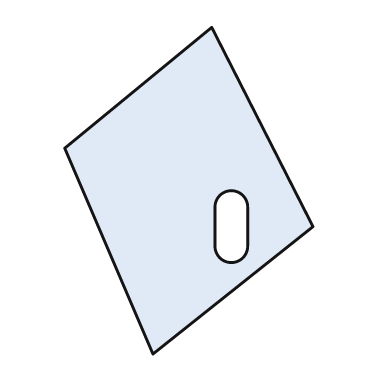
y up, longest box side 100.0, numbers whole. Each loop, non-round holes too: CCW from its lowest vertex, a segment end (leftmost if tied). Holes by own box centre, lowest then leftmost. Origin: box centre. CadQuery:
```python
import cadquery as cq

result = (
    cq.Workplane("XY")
    .moveTo(-11.0, -50.0)
    .lineTo(38.0, -11.0)
    .lineTo(7.0, 50.0)
    .lineTo(-38.0, 13.0)
    .close()
    .moveTo(8.0, -17.0)
    .threePointArc((13.0, -22.0), (18.0, -17.0))
    .lineTo(18.0, -5.0)
    .threePointArc((13.0, 0.0), (8.0, -5.0))
    .close()
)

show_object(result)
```